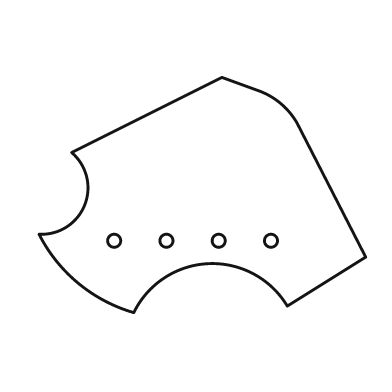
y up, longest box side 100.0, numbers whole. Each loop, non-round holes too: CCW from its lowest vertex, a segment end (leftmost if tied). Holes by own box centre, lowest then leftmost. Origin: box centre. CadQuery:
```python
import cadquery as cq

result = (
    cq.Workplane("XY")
    .moveTo(-21.0, -36.0)
    .threePointArc((2.0, -21.0), (26.0, -34.0))
    .lineTo(50.0, -19.0)
    .lineTo(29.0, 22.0)
    .threePointArc((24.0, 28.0), (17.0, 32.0))
    .lineTo(6.0, 36.0)
    .lineTo(-40.0, 13.0)
    .threePointArc((-36.0, -3.0), (-50.0, -12.0))
    .threePointArc((-38.0, -27.0), (-21.0, -36.0))
    .close()
    .moveTo(-27.0, -14.0)
    .circle(2.0)
    .moveTo(-11.0, -14.0)
    .circle(2.0)
    .moveTo(5.0, -14.0)
    .circle(2.0)
    .moveTo(21.0, -14.0)
    .circle(2.0)
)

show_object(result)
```